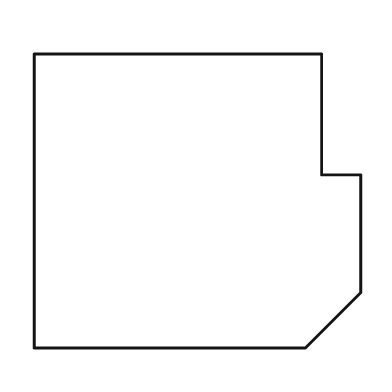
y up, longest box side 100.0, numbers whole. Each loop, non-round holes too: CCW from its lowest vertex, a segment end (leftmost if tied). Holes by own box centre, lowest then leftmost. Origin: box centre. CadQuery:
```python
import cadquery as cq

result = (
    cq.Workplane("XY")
    .moveTo(-50.0, -45.0)
    .lineTo(33.0, -45.0)
    .lineTo(50.0, -28.0)
    .lineTo(50.0, 8.0)
    .lineTo(38.0, 8.0)
    .lineTo(38.0, 45.0)
    .lineTo(-50.0, 45.0)
    .close()
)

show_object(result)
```